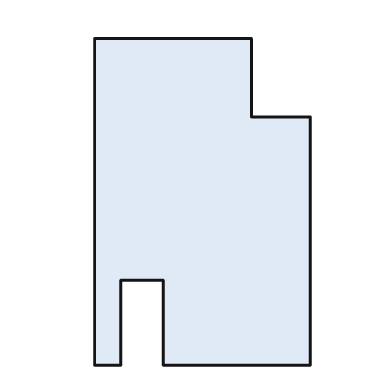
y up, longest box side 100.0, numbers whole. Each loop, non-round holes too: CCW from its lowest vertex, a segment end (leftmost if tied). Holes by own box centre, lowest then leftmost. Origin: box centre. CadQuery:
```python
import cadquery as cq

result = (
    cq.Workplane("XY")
    .moveTo(-33.0, -50.0)
    .lineTo(-25.0, -50.0)
    .lineTo(-25.0, -24.0)
    .lineTo(-12.0, -24.0)
    .lineTo(-12.0, -50.0)
    .lineTo(33.0, -50.0)
    .lineTo(33.0, 26.0)
    .lineTo(15.0, 26.0)
    .lineTo(15.0, 50.0)
    .lineTo(-33.0, 50.0)
    .close()
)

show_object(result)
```